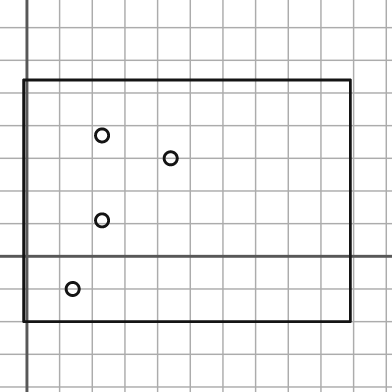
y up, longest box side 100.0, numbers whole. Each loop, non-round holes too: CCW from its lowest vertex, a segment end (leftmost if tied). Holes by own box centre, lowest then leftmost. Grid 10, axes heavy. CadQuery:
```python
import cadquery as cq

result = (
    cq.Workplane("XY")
    .moveTo(-1.0, -20.0)
    .lineTo(99.0, -20.0)
    .lineTo(99.0, 54.0)
    .lineTo(-1.0, 54.0)
    .close()
    .moveTo(14.0, -10.0)
    .circle(2.0)
    .moveTo(23.0, 11.0)
    .circle(2.0)
    .moveTo(44.0, 30.0)
    .circle(2.0)
    .moveTo(23.0, 37.0)
    .circle(2.0)
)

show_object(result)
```